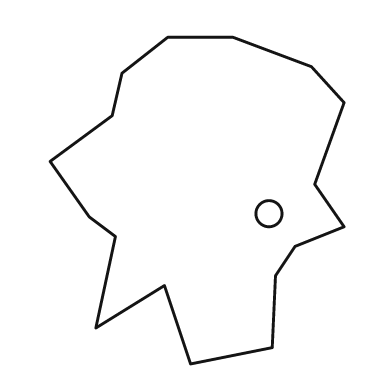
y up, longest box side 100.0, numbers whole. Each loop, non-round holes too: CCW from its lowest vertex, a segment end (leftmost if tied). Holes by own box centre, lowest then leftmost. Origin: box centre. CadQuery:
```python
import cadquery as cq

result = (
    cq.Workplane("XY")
    .moveTo(-2.0, -50.0)
    .lineTo(23.0, -45.0)
    .lineTo(24.0, -23.0)
    .lineTo(30.0, -14.0)
    .lineTo(45.0, -8.0)
    .lineTo(36.0, 5.0)
    .lineTo(45.0, 30.0)
    .lineTo(35.0, 41.0)
    .lineTo(11.0, 50.0)
    .lineTo(-9.0, 50.0)
    .lineTo(-23.0, 39.0)
    .lineTo(-26.0, 26.0)
    .lineTo(-45.0, 12.0)
    .lineTo(-33.0, -5.0)
    .lineTo(-25.0, -11.0)
    .lineTo(-31.0, -39.0)
    .lineTo(-10.0, -26.0)
    .close()
    .moveTo(22.0, -4.0)
    .circle(4.0)
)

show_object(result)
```